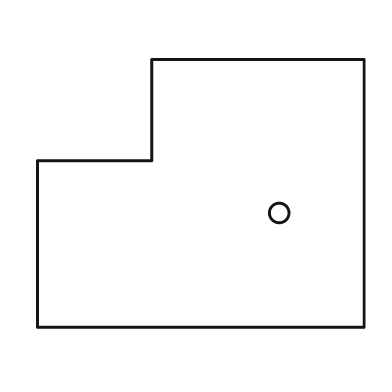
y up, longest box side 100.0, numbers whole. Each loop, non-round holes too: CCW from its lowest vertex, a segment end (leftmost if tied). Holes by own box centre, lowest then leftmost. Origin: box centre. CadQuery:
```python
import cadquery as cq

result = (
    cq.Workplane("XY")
    .moveTo(-50.0, -41.0)
    .lineTo(50.0, -41.0)
    .lineTo(50.0, 41.0)
    .lineTo(-15.0, 41.0)
    .lineTo(-15.0, 10.0)
    .lineTo(-50.0, 10.0)
    .close()
    .moveTo(24.0, -6.0)
    .circle(3.0)
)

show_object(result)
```